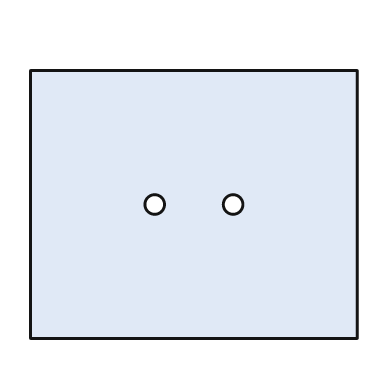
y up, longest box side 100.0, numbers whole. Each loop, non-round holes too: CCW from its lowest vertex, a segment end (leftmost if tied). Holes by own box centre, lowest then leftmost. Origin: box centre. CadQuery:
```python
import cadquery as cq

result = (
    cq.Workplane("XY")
    .moveTo(-50.0, -41.0)
    .lineTo(50.0, -41.0)
    .lineTo(50.0, 41.0)
    .lineTo(-50.0, 41.0)
    .close()
    .moveTo(-12.0, 0.0)
    .circle(3.0)
    .moveTo(12.0, 0.0)
    .circle(3.0)
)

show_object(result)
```